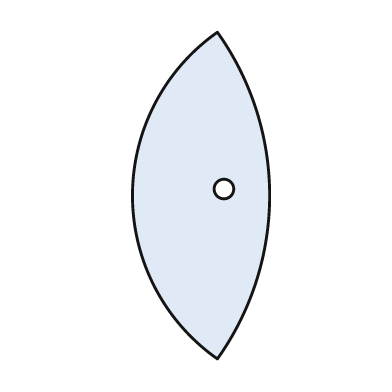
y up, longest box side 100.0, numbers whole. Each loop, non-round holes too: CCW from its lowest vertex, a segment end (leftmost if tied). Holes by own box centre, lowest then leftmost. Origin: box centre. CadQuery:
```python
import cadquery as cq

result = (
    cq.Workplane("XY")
    .moveTo(5.0, -50.0)
    .threePointArc((21.0, 0.0), (5.0, 50.0))
    .threePointArc((-21.0, 0.0), (5.0, -50.0))
    .close()
    .moveTo(7.0, 2.0)
    .circle(3.0)
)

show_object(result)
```